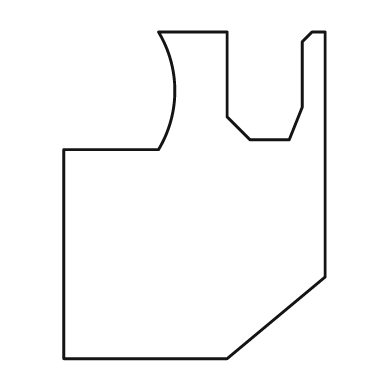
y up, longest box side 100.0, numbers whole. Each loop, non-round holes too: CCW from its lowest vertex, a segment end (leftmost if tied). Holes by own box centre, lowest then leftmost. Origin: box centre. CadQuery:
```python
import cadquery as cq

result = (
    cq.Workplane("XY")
    .moveTo(-40.0, -50.0)
    .lineTo(10.0, -50.0)
    .lineTo(40.0, -25.0)
    .lineTo(40.0, 50.0)
    .lineTo(36.0, 50.0)
    .lineTo(33.0, 47.0)
    .lineTo(33.0, 27.0)
    .lineTo(29.0, 17.0)
    .lineTo(17.0, 17.0)
    .lineTo(10.0, 24.0)
    .lineTo(10.0, 50.0)
    .lineTo(-11.0, 50.0)
    .threePointArc((-6.0, 32.0), (-11.0, 14.0))
    .lineTo(-40.0, 14.0)
    .close()
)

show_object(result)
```